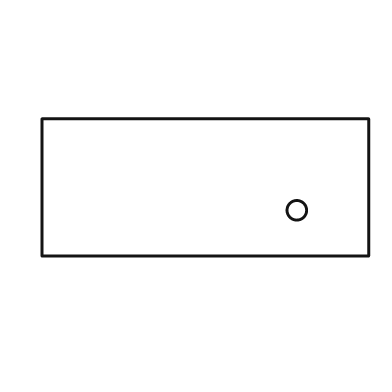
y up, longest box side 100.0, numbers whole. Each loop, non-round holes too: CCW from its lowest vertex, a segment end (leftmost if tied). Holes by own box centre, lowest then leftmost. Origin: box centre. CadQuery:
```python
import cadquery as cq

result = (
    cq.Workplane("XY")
    .moveTo(-50.0, -21.0)
    .lineTo(50.0, -21.0)
    .lineTo(50.0, 21.0)
    .lineTo(-50.0, 21.0)
    .close()
    .moveTo(28.0, -7.0)
    .circle(3.0)
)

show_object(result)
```